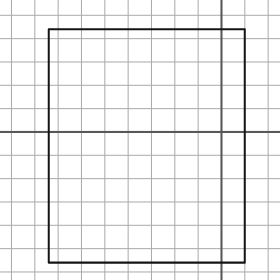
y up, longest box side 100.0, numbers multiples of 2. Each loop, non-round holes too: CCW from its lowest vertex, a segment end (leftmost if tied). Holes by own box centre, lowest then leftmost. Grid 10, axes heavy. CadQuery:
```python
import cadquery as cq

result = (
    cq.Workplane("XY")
    .moveTo(-74.0, -56.0)
    .lineTo(10.0, -56.0)
    .lineTo(10.0, 44.0)
    .lineTo(-74.0, 44.0)
    .close()
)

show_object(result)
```